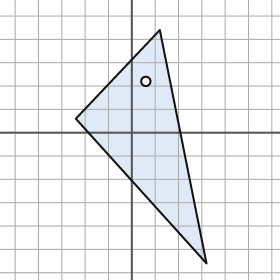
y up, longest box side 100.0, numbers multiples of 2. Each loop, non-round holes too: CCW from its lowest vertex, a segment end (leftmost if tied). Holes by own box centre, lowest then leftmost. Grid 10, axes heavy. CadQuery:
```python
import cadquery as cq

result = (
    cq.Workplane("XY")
    .moveTo(32.0, -56.0)
    .lineTo(12.0, 44.0)
    .lineTo(-24.0, 6.0)
    .close()
    .moveTo(6.0, 22.0)
    .circle(2.0)
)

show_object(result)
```